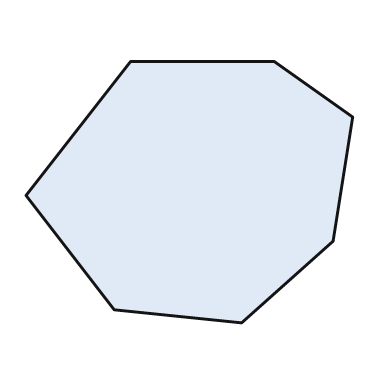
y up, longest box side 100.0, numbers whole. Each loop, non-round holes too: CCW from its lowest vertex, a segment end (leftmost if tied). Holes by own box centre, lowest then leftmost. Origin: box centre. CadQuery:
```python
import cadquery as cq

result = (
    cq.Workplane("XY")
    .moveTo(16.0, -40.0)
    .lineTo(44.0, -15.0)
    .lineTo(50.0, 23.0)
    .lineTo(26.0, 40.0)
    .lineTo(-18.0, 40.0)
    .lineTo(-50.0, -1.0)
    .lineTo(-23.0, -36.0)
    .close()
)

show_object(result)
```